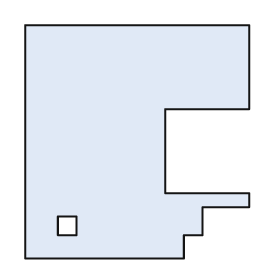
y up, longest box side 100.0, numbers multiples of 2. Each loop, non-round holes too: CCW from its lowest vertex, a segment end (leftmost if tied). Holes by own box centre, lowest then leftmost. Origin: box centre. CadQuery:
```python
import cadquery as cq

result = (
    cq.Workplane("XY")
    .moveTo(-48.0, -50.0)
    .lineTo(20.0, -50.0)
    .lineTo(20.0, -40.0)
    .lineTo(28.0, -40.0)
    .lineTo(28.0, -28.0)
    .lineTo(48.0, -28.0)
    .lineTo(48.0, -22.0)
    .lineTo(12.0, -22.0)
    .lineTo(12.0, 14.0)
    .lineTo(48.0, 14.0)
    .lineTo(48.0, 50.0)
    .lineTo(-48.0, 50.0)
    .close()
    .moveTo(-34.0, -40.0)
    .lineTo(-26.0, -40.0)
    .lineTo(-26.0, -32.0)
    .lineTo(-34.0, -32.0)
    .close()
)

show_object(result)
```